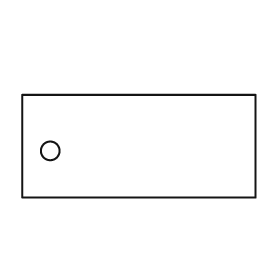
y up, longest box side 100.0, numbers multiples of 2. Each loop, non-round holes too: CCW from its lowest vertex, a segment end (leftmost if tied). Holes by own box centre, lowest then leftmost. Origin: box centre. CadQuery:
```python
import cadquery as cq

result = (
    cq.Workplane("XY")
    .moveTo(-50.0, -22.0)
    .lineTo(50.0, -22.0)
    .lineTo(50.0, 22.0)
    .lineTo(-50.0, 22.0)
    .close()
    .moveTo(-38.0, -2.0)
    .circle(4.0)
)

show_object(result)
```